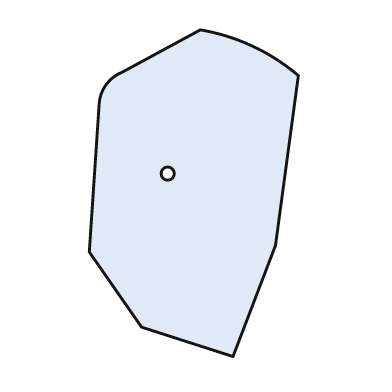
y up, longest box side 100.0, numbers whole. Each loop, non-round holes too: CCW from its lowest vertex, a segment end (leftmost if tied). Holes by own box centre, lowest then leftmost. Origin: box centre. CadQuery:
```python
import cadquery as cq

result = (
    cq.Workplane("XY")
    .moveTo(12.0, -50.0)
    .lineTo(25.0, -16.0)
    .lineTo(32.0, 36.0)
    .threePointArc((18.0, 45.0), (2.0, 50.0))
    .lineTo(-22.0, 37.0)
    .threePointArc((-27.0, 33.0), (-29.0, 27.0))
    .lineTo(-32.0, -18.0)
    .lineTo(-16.0, -41.0)
    .close()
    .moveTo(-8.0, 6.0)
    .circle(2.0)
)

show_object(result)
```